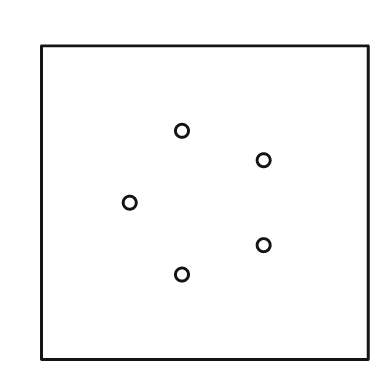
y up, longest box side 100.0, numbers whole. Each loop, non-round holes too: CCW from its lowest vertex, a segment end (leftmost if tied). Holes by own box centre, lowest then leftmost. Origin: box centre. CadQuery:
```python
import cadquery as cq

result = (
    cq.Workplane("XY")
    .moveTo(-50.0, -48.0)
    .lineTo(50.0, -48.0)
    .lineTo(50.0, 48.0)
    .lineTo(-50.0, 48.0)
    .close()
    .moveTo(-7.0, -22.0)
    .circle(2.0)
    .moveTo(18.0, -13.0)
    .circle(2.0)
    .moveTo(-23.0, 0.0)
    .circle(2.0)
    .moveTo(18.0, 13.0)
    .circle(2.0)
    .moveTo(-7.0, 22.0)
    .circle(2.0)
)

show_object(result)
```